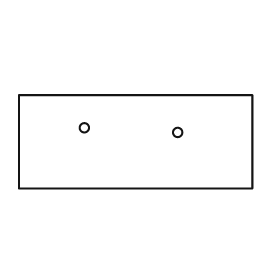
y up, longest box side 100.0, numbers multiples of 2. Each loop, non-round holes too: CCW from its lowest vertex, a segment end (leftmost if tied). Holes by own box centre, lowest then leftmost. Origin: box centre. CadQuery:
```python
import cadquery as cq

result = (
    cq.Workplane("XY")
    .moveTo(-50.0, -20.0)
    .lineTo(50.0, -20.0)
    .lineTo(50.0, 20.0)
    .lineTo(-50.0, 20.0)
    .close()
    .moveTo(18.0, 4.0)
    .circle(2.0)
    .moveTo(-22.0, 6.0)
    .circle(2.0)
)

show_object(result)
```